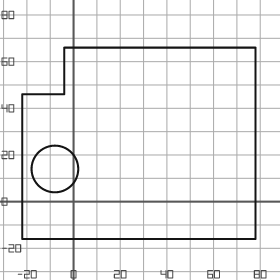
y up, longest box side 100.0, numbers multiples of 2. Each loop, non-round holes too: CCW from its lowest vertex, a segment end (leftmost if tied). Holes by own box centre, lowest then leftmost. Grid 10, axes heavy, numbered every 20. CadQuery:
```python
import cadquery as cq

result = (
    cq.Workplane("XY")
    .moveTo(-22.0, -16.0)
    .lineTo(78.0, -16.0)
    .lineTo(78.0, 66.0)
    .lineTo(-4.0, 66.0)
    .lineTo(-4.0, 46.0)
    .lineTo(-22.0, 46.0)
    .close()
    .moveTo(-8.0, 14.0)
    .circle(10.0)
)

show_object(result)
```